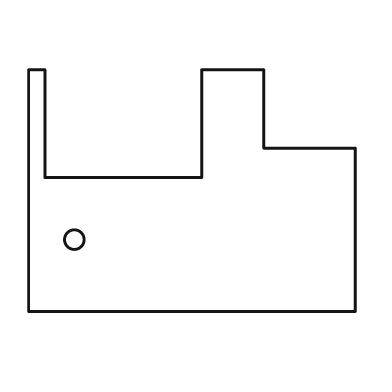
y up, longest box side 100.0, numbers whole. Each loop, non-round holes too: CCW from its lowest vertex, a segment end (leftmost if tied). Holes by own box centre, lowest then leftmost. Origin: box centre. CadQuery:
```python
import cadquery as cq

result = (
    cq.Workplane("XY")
    .moveTo(-50.0, -37.0)
    .lineTo(50.0, -37.0)
    .lineTo(50.0, 13.0)
    .lineTo(22.0, 13.0)
    .lineTo(22.0, 37.0)
    .lineTo(3.0, 37.0)
    .lineTo(3.0, 4.0)
    .lineTo(-45.0, 4.0)
    .lineTo(-45.0, 37.0)
    .lineTo(-50.0, 37.0)
    .close()
    .moveTo(-36.0, -15.0)
    .circle(3.0)
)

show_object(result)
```